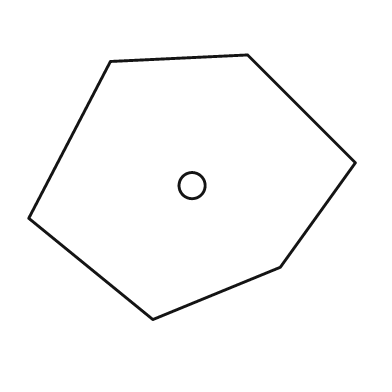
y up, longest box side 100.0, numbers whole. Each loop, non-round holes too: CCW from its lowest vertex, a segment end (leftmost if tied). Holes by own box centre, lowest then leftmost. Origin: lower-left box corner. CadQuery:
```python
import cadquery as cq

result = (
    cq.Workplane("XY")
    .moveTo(38.0, 0.0)
    .lineTo(77.0, 16.0)
    .lineTo(100.0, 48.0)
    .lineTo(67.0, 81.0)
    .lineTo(25.0, 79.0)
    .lineTo(0.0, 31.0)
    .close()
    .moveTo(50.0, 41.0)
    .circle(4.0)
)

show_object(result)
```